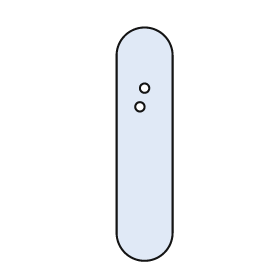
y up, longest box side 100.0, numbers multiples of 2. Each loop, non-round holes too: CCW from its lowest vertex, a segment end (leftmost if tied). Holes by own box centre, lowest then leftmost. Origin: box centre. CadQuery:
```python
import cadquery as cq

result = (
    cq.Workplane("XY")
    .moveTo(-12.0, -38.0)
    .threePointArc((0.0, -50.0), (12.0, -38.0))
    .lineTo(12.0, 38.0)
    .threePointArc((0.0, 50.0), (-12.0, 38.0))
    .close()
    .moveTo(-2.0, 16.0)
    .circle(2.0)
    .moveTo(0.0, 24.0)
    .circle(2.0)
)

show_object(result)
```